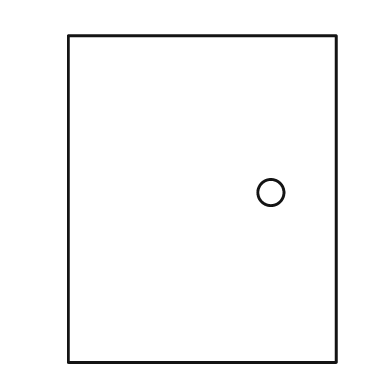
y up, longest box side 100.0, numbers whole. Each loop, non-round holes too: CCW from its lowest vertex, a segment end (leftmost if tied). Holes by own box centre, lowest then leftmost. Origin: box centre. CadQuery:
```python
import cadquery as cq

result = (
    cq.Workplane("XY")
    .moveTo(-41.0, -50.0)
    .lineTo(41.0, -50.0)
    .lineTo(41.0, 50.0)
    .lineTo(-41.0, 50.0)
    .close()
    .moveTo(21.0, 2.0)
    .circle(4.0)
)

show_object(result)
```